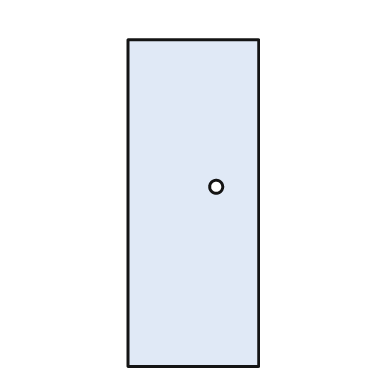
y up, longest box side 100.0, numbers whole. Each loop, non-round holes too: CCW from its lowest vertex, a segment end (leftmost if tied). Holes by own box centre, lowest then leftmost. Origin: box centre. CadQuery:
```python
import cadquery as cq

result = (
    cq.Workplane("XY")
    .moveTo(-20.0, -50.0)
    .lineTo(20.0, -50.0)
    .lineTo(20.0, 50.0)
    .lineTo(-20.0, 50.0)
    .close()
    .moveTo(7.0, 5.0)
    .circle(2.0)
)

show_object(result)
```